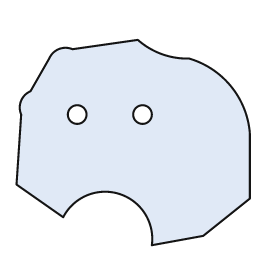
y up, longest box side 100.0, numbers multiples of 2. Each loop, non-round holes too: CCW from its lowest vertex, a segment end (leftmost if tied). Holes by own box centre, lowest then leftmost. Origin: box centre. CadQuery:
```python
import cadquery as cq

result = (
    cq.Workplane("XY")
    .moveTo(8.0, -44.0)
    .lineTo(30.0, -40.0)
    .lineTo(50.0, -24.0)
    .lineTo(50.0, 4.0)
    .threePointArc((42.0, 24.0), (24.0, 36.0))
    .threePointArc((12.0, 38.0), (2.0, 44.0))
    .lineTo(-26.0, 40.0)
    .threePointArc((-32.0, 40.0), (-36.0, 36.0))
    .lineTo(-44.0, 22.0)
    .threePointArc((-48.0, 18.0), (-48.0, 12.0))
    .lineTo(-50.0, -18.0)
    .lineTo(-30.0, -32.0)
    .threePointArc((-6.0, -22.0), (8.0, -44.0))
    .close()
    .moveTo(-24.0, 12.0)
    .circle(4.0)
    .moveTo(4.0, 12.0)
    .circle(4.0)
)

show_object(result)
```